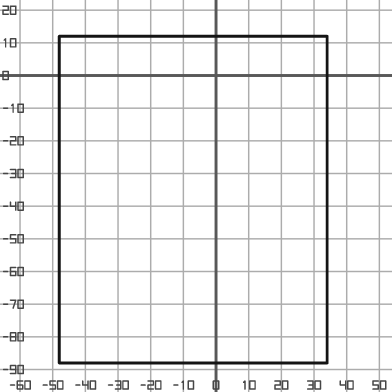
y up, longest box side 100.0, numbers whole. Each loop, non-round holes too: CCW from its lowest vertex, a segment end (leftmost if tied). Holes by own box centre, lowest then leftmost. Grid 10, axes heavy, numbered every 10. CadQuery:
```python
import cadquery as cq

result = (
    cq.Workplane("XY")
    .moveTo(-48.0, -88.0)
    .lineTo(34.0, -88.0)
    .lineTo(34.0, 12.0)
    .lineTo(-48.0, 12.0)
    .close()
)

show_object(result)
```